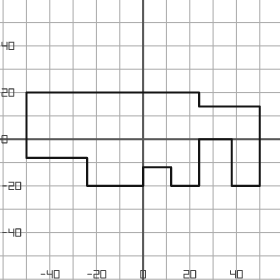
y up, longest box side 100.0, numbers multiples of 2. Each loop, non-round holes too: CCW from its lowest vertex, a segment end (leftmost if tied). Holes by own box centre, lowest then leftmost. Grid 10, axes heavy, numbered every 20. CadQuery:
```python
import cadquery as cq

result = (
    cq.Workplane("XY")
    .moveTo(-24.0, -20.0)
    .lineTo(0.0, -20.0)
    .lineTo(0.0, -12.0)
    .lineTo(12.0, -12.0)
    .lineTo(12.0, -20.0)
    .lineTo(24.0, -20.0)
    .lineTo(24.0, 0.0)
    .lineTo(38.0, 0.0)
    .lineTo(38.0, -20.0)
    .lineTo(50.0, -20.0)
    .lineTo(50.0, 14.0)
    .lineTo(24.0, 14.0)
    .lineTo(24.0, 20.0)
    .lineTo(-50.0, 20.0)
    .lineTo(-50.0, -8.0)
    .lineTo(-24.0, -8.0)
    .close()
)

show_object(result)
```